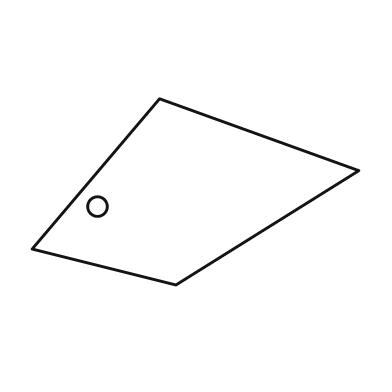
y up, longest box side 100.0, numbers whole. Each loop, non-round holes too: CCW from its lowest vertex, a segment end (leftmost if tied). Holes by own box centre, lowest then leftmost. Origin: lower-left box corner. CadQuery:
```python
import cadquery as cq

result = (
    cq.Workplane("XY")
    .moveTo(44.0, 0.0)
    .lineTo(100.0, 35.0)
    .lineTo(39.0, 57.0)
    .lineTo(0.0, 11.0)
    .close()
    .moveTo(20.0, 24.0)
    .circle(3.0)
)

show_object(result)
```